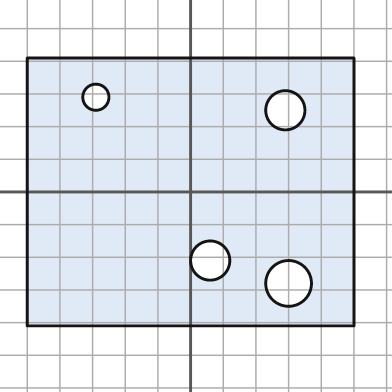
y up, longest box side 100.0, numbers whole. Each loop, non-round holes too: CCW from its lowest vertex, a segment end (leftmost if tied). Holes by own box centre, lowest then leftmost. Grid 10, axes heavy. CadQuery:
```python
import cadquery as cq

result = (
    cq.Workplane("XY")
    .moveTo(-50.0, -41.0)
    .lineTo(50.0, -41.0)
    .lineTo(50.0, 41.0)
    .lineTo(-50.0, 41.0)
    .close()
    .moveTo(30.0, -28.0)
    .circle(7.0)
    .moveTo(6.0, -21.0)
    .circle(6.0)
    .moveTo(29.0, 25.0)
    .circle(6.0)
    .moveTo(-29.0, 29.0)
    .circle(4.0)
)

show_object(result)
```